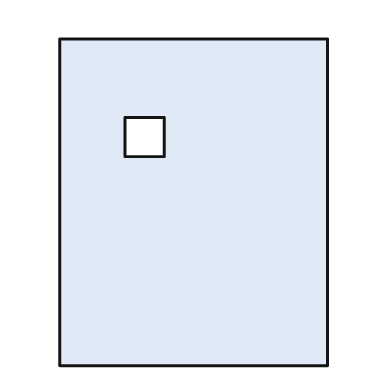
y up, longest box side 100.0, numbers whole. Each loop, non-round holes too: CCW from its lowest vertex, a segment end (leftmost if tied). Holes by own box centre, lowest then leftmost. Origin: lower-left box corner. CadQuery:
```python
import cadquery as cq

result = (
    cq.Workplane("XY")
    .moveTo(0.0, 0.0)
    .lineTo(82.0, 0.0)
    .lineTo(82.0, 100.0)
    .lineTo(0.0, 100.0)
    .close()
    .moveTo(20.0, 64.0)
    .lineTo(32.0, 64.0)
    .lineTo(32.0, 76.0)
    .lineTo(20.0, 76.0)
    .close()
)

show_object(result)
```